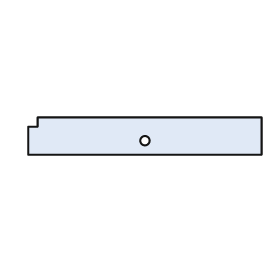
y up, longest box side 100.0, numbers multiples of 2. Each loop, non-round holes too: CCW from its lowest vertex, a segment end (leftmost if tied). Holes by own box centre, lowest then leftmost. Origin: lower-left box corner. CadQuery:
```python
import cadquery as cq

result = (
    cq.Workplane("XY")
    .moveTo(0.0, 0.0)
    .lineTo(100.0, 0.0)
    .lineTo(100.0, 16.0)
    .lineTo(4.0, 16.0)
    .lineTo(4.0, 12.0)
    .lineTo(0.0, 12.0)
    .close()
    .moveTo(50.0, 6.0)
    .circle(2.0)
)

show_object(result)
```